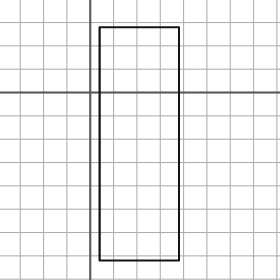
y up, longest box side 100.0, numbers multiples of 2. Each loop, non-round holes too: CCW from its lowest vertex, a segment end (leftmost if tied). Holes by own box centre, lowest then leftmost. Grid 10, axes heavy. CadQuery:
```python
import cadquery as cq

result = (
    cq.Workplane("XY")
    .moveTo(4.0, -72.0)
    .lineTo(38.0, -72.0)
    .lineTo(38.0, 28.0)
    .lineTo(4.0, 28.0)
    .close()
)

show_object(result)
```